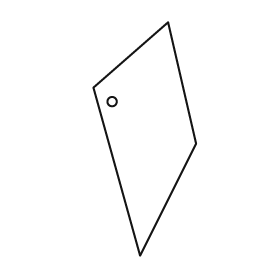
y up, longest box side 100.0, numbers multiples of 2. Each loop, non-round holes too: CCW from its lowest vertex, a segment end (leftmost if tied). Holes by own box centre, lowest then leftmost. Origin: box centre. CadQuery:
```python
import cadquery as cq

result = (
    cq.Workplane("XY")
    .moveTo(-2.0, -50.0)
    .lineTo(22.0, -2.0)
    .lineTo(10.0, 50.0)
    .lineTo(-22.0, 22.0)
    .close()
    .moveTo(-14.0, 16.0)
    .circle(2.0)
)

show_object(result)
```